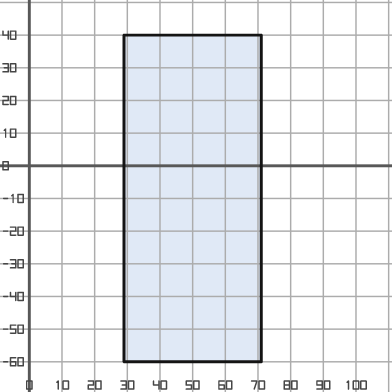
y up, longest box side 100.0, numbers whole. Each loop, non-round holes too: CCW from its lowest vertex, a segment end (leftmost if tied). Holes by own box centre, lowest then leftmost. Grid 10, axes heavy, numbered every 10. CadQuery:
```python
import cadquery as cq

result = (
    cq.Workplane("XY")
    .moveTo(29.0, -60.0)
    .lineTo(71.0, -60.0)
    .lineTo(71.0, 40.0)
    .lineTo(29.0, 40.0)
    .close()
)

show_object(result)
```